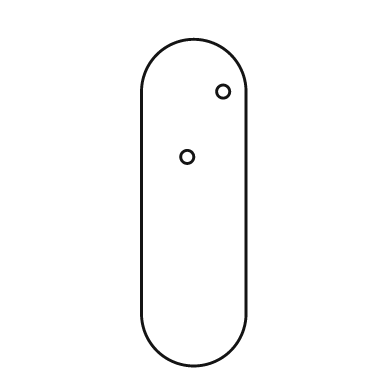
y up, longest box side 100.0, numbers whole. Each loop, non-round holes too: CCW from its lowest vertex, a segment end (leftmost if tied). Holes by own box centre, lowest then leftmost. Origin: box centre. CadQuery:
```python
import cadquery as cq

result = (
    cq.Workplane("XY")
    .moveTo(-16.0, -34.0)
    .threePointArc((0.0, -50.0), (16.0, -34.0))
    .lineTo(16.0, 34.0)
    .threePointArc((0.0, 50.0), (-16.0, 34.0))
    .close()
    .moveTo(-2.0, 14.0)
    .circle(2.0)
    .moveTo(9.0, 34.0)
    .circle(2.0)
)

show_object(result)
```